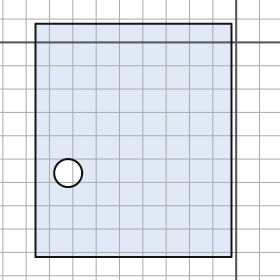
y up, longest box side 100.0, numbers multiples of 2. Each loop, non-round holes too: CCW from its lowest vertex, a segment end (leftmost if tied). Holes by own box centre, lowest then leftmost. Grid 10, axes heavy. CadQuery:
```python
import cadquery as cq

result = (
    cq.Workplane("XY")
    .moveTo(-86.0, -92.0)
    .lineTo(-2.0, -92.0)
    .lineTo(-2.0, 8.0)
    .lineTo(-86.0, 8.0)
    .close()
    .moveTo(-72.0, -56.0)
    .circle(6.0)
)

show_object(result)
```